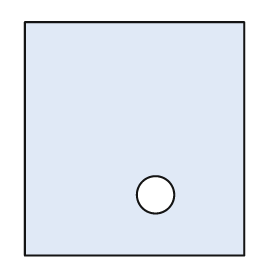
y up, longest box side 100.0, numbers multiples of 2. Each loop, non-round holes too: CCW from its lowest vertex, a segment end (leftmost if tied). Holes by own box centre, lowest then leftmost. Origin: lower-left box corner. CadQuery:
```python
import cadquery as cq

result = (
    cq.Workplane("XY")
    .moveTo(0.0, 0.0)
    .lineTo(94.0, 0.0)
    .lineTo(94.0, 100.0)
    .lineTo(0.0, 100.0)
    .close()
    .moveTo(56.0, 26.0)
    .circle(8.0)
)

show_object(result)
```